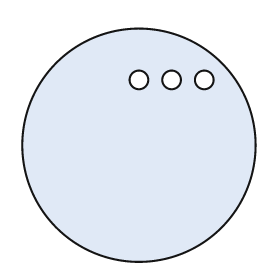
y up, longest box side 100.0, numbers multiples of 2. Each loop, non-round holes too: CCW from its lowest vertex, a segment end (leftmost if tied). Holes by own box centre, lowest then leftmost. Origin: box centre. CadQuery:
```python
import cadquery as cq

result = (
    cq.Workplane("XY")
    .moveTo(0.0, 0.0)
    .circle(50.0)
    .moveTo(0.0, 28.0)
    .circle(4.0)
    .moveTo(14.0, 28.0)
    .circle(4.0)
    .moveTo(28.0, 28.0)
    .circle(4.0)
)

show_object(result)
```